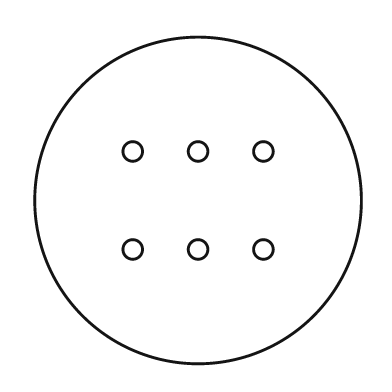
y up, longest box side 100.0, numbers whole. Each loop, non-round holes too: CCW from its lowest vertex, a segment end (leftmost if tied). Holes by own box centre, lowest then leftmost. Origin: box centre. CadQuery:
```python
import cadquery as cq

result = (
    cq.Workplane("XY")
    .moveTo(0.0, 0.0)
    .circle(50.0)
    .moveTo(-20.0, -15.0)
    .circle(3.0)
    .moveTo(0.0, -15.0)
    .circle(3.0)
    .moveTo(20.0, -15.0)
    .circle(3.0)
    .moveTo(-20.0, 15.0)
    .circle(3.0)
    .moveTo(0.0, 15.0)
    .circle(3.0)
    .moveTo(20.0, 15.0)
    .circle(3.0)
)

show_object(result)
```